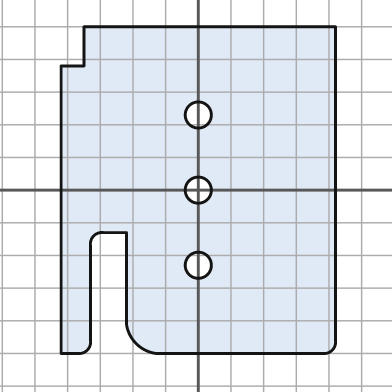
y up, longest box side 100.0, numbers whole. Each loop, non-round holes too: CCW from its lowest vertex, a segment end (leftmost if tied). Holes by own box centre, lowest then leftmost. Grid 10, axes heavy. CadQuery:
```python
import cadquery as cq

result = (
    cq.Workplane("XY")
    .moveTo(-42.0, -50.0)
    .lineTo(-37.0, -50.0)
    .threePointArc((-34.0, -49.0), (-33.0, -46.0))
    .lineTo(-33.0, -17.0)
    .threePointArc((-32.0, -14.0), (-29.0, -13.0))
    .lineTo(-22.0, -13.0)
    .lineTo(-22.0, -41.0)
    .threePointArc((-19.0, -47.0), (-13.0, -50.0))
    .lineTo(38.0, -50.0)
    .threePointArc((41.0, -49.0), (42.0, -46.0))
    .lineTo(42.0, 50.0)
    .lineTo(-35.0, 50.0)
    .lineTo(-35.0, 38.0)
    .lineTo(-42.0, 38.0)
    .close()
    .moveTo(0.0, -23.0)
    .circle(4.0)
    .moveTo(0.0, 0.0)
    .circle(4.0)
    .moveTo(0.0, 23.0)
    .circle(4.0)
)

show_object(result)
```